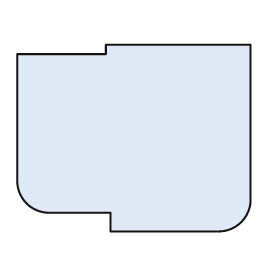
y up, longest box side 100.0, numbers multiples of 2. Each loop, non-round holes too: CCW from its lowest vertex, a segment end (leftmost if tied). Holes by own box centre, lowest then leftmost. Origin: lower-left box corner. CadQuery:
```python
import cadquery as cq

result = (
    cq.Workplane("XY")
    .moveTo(40.0, 0.0)
    .lineTo(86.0, 0.0)
    .threePointArc((96.0, 4.0), (100.0, 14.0))
    .lineTo(100.0, 80.0)
    .lineTo(38.0, 80.0)
    .lineTo(38.0, 76.0)
    .lineTo(0.0, 76.0)
    .lineTo(0.0, 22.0)
    .threePointArc((4.0, 12.0), (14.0, 8.0))
    .lineTo(40.0, 8.0)
    .close()
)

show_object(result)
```